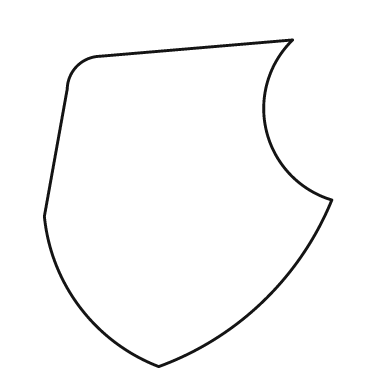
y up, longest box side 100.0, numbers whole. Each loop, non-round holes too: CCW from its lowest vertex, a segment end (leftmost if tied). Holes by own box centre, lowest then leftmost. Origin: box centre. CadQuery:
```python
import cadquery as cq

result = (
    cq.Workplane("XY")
    .moveTo(-9.0, -50.0)
    .threePointArc((23.0, -30.0), (44.0, 1.0))
    .threePointArc((24.0, 22.0), (32.0, 50.0))
    .lineTo(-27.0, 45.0)
    .threePointArc((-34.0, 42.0), (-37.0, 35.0))
    .lineTo(-44.0, -4.0)
    .threePointArc((-33.0, -32.0), (-9.0, -50.0))
    .close()
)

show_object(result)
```